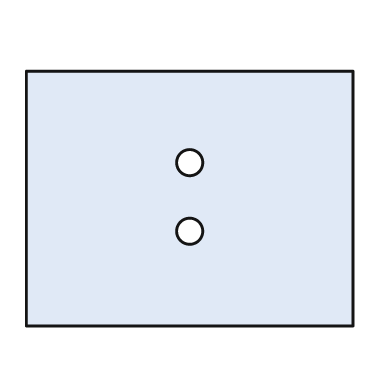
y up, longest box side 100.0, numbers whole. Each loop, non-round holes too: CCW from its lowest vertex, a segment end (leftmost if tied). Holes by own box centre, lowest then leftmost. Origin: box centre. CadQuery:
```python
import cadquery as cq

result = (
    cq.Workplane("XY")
    .moveTo(-50.0, -39.0)
    .lineTo(50.0, -39.0)
    .lineTo(50.0, 39.0)
    .lineTo(-50.0, 39.0)
    .close()
    .moveTo(0.0, -10.0)
    .circle(4.0)
    .moveTo(0.0, 11.0)
    .circle(4.0)
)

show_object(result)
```